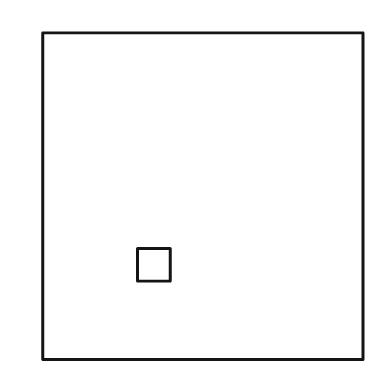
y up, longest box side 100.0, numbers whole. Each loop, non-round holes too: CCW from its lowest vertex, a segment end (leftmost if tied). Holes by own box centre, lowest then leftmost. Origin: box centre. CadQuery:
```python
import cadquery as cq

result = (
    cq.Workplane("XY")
    .moveTo(-49.0, -50.0)
    .lineTo(49.0, -50.0)
    .lineTo(49.0, 50.0)
    .lineTo(-49.0, 50.0)
    .close()
    .moveTo(-20.0, -26.0)
    .lineTo(-10.0, -26.0)
    .lineTo(-10.0, -16.0)
    .lineTo(-20.0, -16.0)
    .close()
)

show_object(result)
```